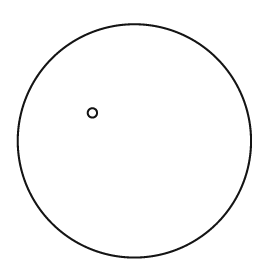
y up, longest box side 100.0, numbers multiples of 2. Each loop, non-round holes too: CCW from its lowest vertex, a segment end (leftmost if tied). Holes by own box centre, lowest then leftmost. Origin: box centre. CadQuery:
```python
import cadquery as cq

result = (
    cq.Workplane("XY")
    .moveTo(0.0, 0.0)
    .circle(50.0)
    .moveTo(-18.0, 12.0)
    .circle(2.0)
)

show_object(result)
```